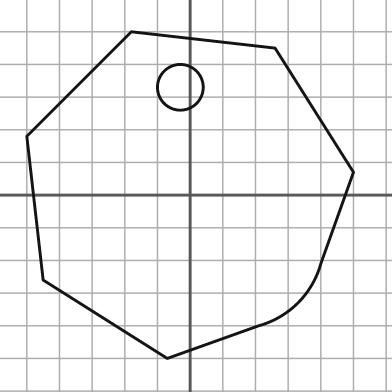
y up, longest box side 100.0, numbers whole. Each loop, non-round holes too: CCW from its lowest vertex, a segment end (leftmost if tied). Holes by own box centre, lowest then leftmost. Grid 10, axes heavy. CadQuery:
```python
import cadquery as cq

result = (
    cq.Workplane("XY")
    .moveTo(-7.0, -50.0)
    .lineTo(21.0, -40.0)
    .threePointArc((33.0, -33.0), (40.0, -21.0))
    .lineTo(50.0, 7.0)
    .lineTo(26.0, 45.0)
    .lineTo(-18.0, 50.0)
    .lineTo(-50.0, 18.0)
    .lineTo(-45.0, -26.0)
    .close()
    .moveTo(-3.0, 33.0)
    .circle(7.0)
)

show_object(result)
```